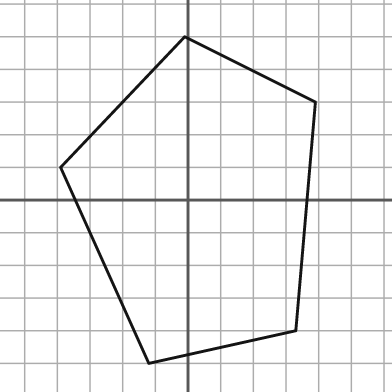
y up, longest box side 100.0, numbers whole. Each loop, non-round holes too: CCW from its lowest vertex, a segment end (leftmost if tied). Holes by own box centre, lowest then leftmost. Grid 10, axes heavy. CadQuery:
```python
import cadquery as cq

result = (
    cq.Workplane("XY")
    .moveTo(-12.0, -50.0)
    .lineTo(33.0, -40.0)
    .lineTo(39.0, 30.0)
    .lineTo(-1.0, 50.0)
    .lineTo(-39.0, 10.0)
    .close()
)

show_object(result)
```